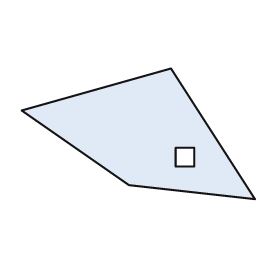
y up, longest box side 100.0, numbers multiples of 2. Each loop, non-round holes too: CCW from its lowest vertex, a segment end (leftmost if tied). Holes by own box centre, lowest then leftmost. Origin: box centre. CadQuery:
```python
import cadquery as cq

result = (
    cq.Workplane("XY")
    .moveTo(50.0, -28.0)
    .lineTo(14.0, 28.0)
    .lineTo(-50.0, 10.0)
    .lineTo(-4.0, -22.0)
    .close()
    .moveTo(16.0, -14.0)
    .lineTo(24.0, -14.0)
    .lineTo(24.0, -6.0)
    .lineTo(16.0, -6.0)
    .close()
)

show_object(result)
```